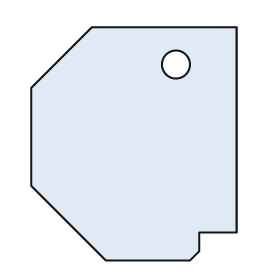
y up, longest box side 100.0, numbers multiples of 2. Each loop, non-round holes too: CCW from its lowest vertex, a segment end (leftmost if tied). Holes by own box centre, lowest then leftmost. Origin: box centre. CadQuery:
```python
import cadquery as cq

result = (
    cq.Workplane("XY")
    .moveTo(-12.0, -50.0)
    .lineTo(24.0, -50.0)
    .lineTo(28.0, -46.0)
    .lineTo(28.0, -38.0)
    .lineTo(44.0, -38.0)
    .lineTo(44.0, 50.0)
    .lineTo(-18.0, 50.0)
    .lineTo(-44.0, 24.0)
    .lineTo(-44.0, -18.0)
    .close()
    .moveTo(18.0, 34.0)
    .circle(6.0)
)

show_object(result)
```